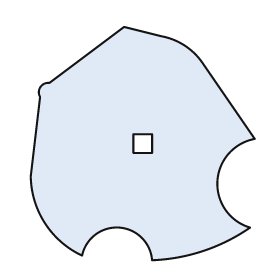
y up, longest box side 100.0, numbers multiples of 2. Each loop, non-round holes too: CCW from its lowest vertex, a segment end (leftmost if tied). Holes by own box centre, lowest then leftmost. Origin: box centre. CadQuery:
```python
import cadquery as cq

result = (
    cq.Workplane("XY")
    .moveTo(4.0, -50.0)
    .threePointArc((26.0, -46.0), (46.0, -36.0))
    .threePointArc((32.0, -16.0), (48.0, 2.0))
    .lineTo(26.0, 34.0)
    .threePointArc((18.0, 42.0), (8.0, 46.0))
    .lineTo(-8.0, 50.0)
    .lineTo(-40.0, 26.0)
    .threePointArc((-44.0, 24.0), (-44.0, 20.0))
    .lineTo(-48.0, -14.0)
    .threePointArc((-42.0, -34.0), (-26.0, -48.0))
    .threePointArc((-10.0, -36.0), (4.0, -50.0))
    .close()
    .moveTo(-4.0, -4.0)
    .lineTo(4.0, -4.0)
    .lineTo(4.0, 4.0)
    .lineTo(-4.0, 4.0)
    .close()
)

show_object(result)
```